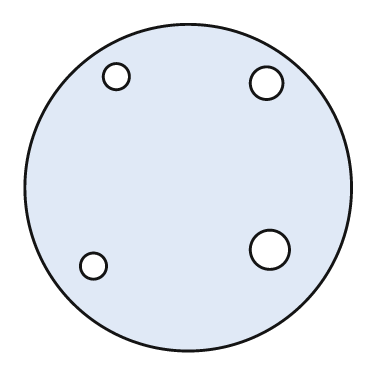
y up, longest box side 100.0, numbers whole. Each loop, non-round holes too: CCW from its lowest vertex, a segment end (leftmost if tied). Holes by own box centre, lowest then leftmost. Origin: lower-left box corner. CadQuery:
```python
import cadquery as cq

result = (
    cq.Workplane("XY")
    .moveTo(50.0, 50.0)
    .circle(50.0)
    .moveTo(21.0, 26.0)
    .circle(4.0)
    .moveTo(75.0, 31.0)
    .circle(6.0)
    .moveTo(74.0, 82.0)
    .circle(5.0)
    .moveTo(28.0, 84.0)
    .circle(4.0)
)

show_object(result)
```